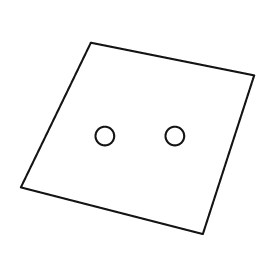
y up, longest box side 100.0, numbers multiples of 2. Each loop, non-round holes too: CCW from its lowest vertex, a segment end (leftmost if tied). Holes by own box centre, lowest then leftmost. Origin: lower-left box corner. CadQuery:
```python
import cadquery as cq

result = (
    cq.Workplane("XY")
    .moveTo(78.0, 0.0)
    .lineTo(100.0, 68.0)
    .lineTo(30.0, 82.0)
    .lineTo(0.0, 20.0)
    .close()
    .moveTo(36.0, 42.0)
    .circle(4.0)
    .moveTo(66.0, 42.0)
    .circle(4.0)
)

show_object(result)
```